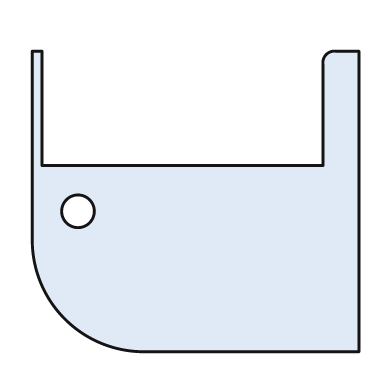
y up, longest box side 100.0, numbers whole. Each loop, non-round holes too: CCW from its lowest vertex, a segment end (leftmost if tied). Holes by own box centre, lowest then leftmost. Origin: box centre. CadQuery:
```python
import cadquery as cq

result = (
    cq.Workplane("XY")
    .moveTo(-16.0, -46.0)
    .lineTo(50.0, -46.0)
    .lineTo(50.0, 46.0)
    .lineTo(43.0, 46.0)
    .threePointArc((40.0, 45.0), (39.0, 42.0))
    .lineTo(39.0, 11.0)
    .lineTo(-47.0, 11.0)
    .lineTo(-47.0, 46.0)
    .lineTo(-50.0, 46.0)
    .lineTo(-50.0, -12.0)
    .threePointArc((-40.0, -36.0), (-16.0, -46.0))
    .close()
    .moveTo(-36.0, -3.0)
    .circle(5.0)
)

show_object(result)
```